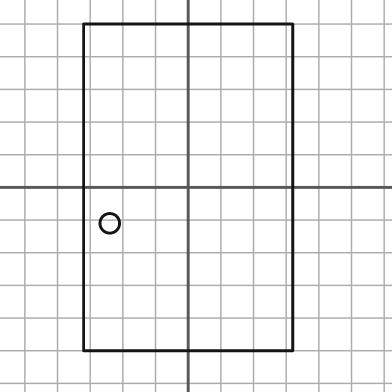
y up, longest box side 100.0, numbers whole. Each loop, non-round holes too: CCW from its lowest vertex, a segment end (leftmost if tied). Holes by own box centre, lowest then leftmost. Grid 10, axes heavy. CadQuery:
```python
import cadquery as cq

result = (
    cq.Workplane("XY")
    .moveTo(-32.0, -50.0)
    .lineTo(32.0, -50.0)
    .lineTo(32.0, 50.0)
    .lineTo(-32.0, 50.0)
    .close()
    .moveTo(-24.0, -11.0)
    .circle(3.0)
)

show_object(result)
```